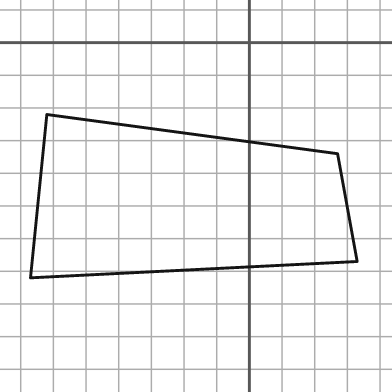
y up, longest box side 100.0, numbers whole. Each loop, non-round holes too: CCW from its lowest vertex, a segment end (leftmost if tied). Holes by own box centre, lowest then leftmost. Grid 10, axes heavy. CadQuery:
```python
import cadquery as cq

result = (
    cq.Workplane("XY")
    .moveTo(-67.0, -72.0)
    .lineTo(33.0, -67.0)
    .lineTo(27.0, -34.0)
    .lineTo(-62.0, -22.0)
    .close()
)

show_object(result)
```